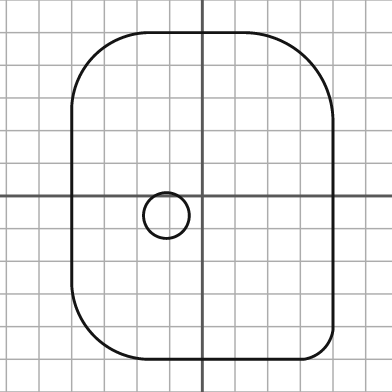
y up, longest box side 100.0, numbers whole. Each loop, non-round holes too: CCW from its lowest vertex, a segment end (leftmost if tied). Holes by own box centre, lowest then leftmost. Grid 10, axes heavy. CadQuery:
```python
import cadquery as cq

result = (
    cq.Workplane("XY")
    .moveTo(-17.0, -50.0)
    .lineTo(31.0, -50.0)
    .threePointArc((37.0, -47.0), (40.0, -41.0))
    .lineTo(40.0, 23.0)
    .threePointArc((32.0, 42.0), (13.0, 50.0))
    .lineTo(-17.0, 50.0)
    .threePointArc((-33.0, 43.0), (-40.0, 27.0))
    .lineTo(-40.0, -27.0)
    .threePointArc((-33.0, -43.0), (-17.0, -50.0))
    .close()
    .moveTo(-11.0, -6.0)
    .circle(7.0)
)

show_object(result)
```